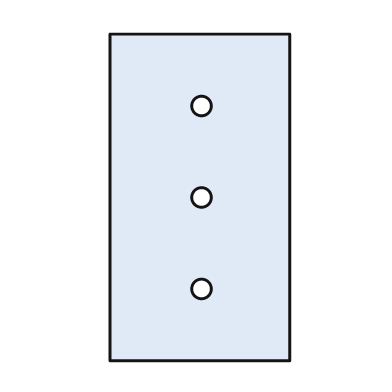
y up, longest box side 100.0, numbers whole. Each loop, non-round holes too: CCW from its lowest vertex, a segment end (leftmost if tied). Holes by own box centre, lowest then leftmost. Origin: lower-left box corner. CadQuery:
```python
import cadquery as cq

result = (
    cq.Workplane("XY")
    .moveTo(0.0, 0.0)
    .lineTo(55.0, 0.0)
    .lineTo(55.0, 100.0)
    .lineTo(0.0, 100.0)
    .close()
    .moveTo(28.0, 22.0)
    .circle(3.0)
    .moveTo(28.0, 50.0)
    .circle(3.0)
    .moveTo(28.0, 78.0)
    .circle(3.0)
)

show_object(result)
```